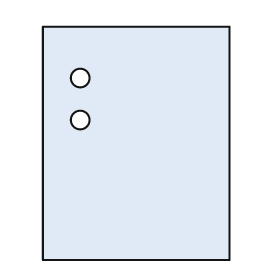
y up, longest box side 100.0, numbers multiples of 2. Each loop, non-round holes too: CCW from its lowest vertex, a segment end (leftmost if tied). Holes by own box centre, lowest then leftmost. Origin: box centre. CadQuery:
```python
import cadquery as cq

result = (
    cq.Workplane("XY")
    .moveTo(-40.0, -50.0)
    .lineTo(40.0, -50.0)
    .lineTo(40.0, 50.0)
    .lineTo(-40.0, 50.0)
    .close()
    .moveTo(-24.0, 10.0)
    .circle(4.0)
    .moveTo(-24.0, 28.0)
    .circle(4.0)
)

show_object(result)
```